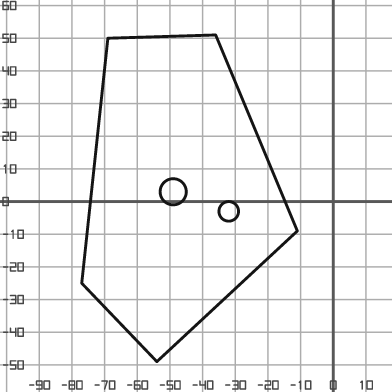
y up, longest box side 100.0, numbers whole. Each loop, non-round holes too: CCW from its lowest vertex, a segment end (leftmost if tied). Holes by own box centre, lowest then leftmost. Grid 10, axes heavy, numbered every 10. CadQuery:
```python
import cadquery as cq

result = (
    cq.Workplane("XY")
    .moveTo(-54.0, -49.0)
    .lineTo(-11.0, -9.0)
    .lineTo(-36.0, 51.0)
    .lineTo(-69.0, 50.0)
    .lineTo(-77.0, -25.0)
    .close()
    .moveTo(-32.0, -3.0)
    .circle(3.0)
    .moveTo(-49.0, 3.0)
    .circle(4.0)
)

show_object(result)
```